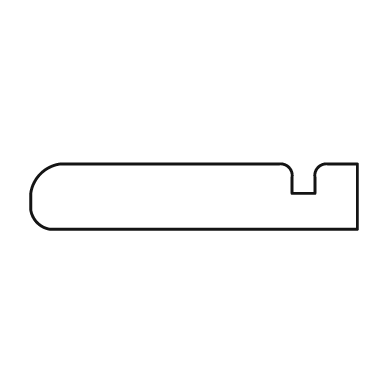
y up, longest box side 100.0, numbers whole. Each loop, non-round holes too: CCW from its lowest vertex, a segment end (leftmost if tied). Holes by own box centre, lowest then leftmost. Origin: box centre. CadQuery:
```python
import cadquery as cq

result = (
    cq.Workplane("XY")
    .moveTo(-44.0, -10.0)
    .lineTo(50.0, -10.0)
    .lineTo(50.0, 10.0)
    .lineTo(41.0, 10.0)
    .threePointArc((38.0, 9.0), (37.0, 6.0))
    .lineTo(37.0, 1.0)
    .lineTo(30.0, 1.0)
    .lineTo(30.0, 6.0)
    .threePointArc((29.0, 9.0), (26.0, 10.0))
    .lineTo(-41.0, 10.0)
    .threePointArc((-47.0, 7.0), (-50.0, 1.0))
    .lineTo(-50.0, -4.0)
    .threePointArc((-48.0, -8.0), (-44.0, -10.0))
    .close()
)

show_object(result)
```